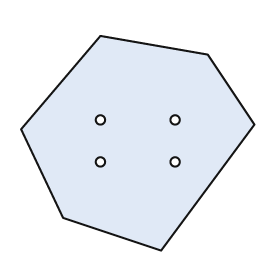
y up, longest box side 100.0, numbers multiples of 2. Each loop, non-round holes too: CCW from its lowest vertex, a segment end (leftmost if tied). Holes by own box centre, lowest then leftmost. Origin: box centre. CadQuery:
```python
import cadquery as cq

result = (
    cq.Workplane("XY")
    .moveTo(10.0, -46.0)
    .lineTo(50.0, 8.0)
    .lineTo(30.0, 38.0)
    .lineTo(-16.0, 46.0)
    .lineTo(-50.0, 6.0)
    .lineTo(-32.0, -32.0)
    .close()
    .moveTo(-16.0, -8.0)
    .circle(2.0)
    .moveTo(16.0, -8.0)
    .circle(2.0)
    .moveTo(-16.0, 10.0)
    .circle(2.0)
    .moveTo(16.0, 10.0)
    .circle(2.0)
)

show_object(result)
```